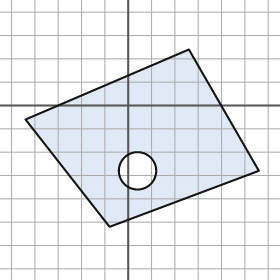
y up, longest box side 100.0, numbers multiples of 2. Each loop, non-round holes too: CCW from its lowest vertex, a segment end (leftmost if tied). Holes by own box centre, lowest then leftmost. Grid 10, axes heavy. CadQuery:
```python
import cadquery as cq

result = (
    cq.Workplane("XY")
    .moveTo(-8.0, -52.0)
    .lineTo(56.0, -28.0)
    .lineTo(26.0, 24.0)
    .lineTo(-44.0, -6.0)
    .close()
    .moveTo(4.0, -28.0)
    .circle(8.0)
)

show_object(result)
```